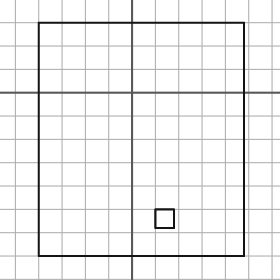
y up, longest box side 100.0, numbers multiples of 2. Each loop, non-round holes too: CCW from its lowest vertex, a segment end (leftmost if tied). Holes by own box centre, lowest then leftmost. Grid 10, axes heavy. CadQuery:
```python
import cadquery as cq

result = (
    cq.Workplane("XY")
    .moveTo(-40.0, -70.0)
    .lineTo(48.0, -70.0)
    .lineTo(48.0, 30.0)
    .lineTo(-40.0, 30.0)
    .close()
    .moveTo(10.0, -58.0)
    .lineTo(18.0, -58.0)
    .lineTo(18.0, -50.0)
    .lineTo(10.0, -50.0)
    .close()
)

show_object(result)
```